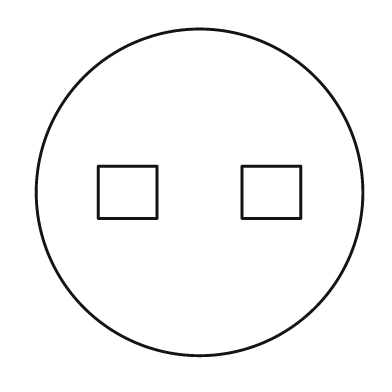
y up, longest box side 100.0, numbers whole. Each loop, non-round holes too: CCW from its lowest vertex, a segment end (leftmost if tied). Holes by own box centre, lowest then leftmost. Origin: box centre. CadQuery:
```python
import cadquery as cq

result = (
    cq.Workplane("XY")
    .moveTo(0.0, 0.0)
    .circle(50.0)
    .moveTo(-31.0, -8.0)
    .lineTo(-13.0, -8.0)
    .lineTo(-13.0, 8.0)
    .lineTo(-31.0, 8.0)
    .close()
    .moveTo(13.0, -8.0)
    .lineTo(31.0, -8.0)
    .lineTo(31.0, 8.0)
    .lineTo(13.0, 8.0)
    .close()
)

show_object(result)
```